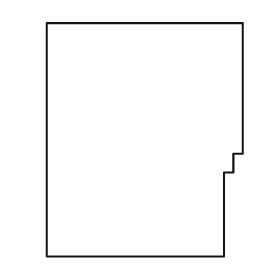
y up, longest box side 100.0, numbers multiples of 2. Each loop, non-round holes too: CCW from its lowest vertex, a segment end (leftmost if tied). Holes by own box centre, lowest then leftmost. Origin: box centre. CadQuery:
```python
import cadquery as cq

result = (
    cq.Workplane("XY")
    .moveTo(-42.0, -50.0)
    .lineTo(34.0, -50.0)
    .lineTo(34.0, -14.0)
    .lineTo(38.0, -14.0)
    .lineTo(38.0, -6.0)
    .lineTo(42.0, -6.0)
    .lineTo(42.0, 50.0)
    .lineTo(-42.0, 50.0)
    .close()
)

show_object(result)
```